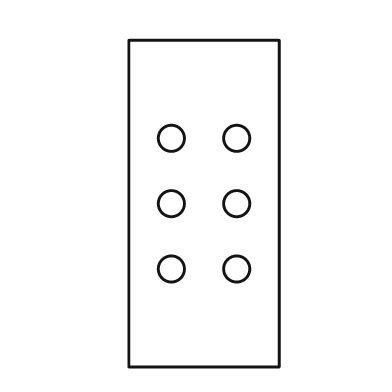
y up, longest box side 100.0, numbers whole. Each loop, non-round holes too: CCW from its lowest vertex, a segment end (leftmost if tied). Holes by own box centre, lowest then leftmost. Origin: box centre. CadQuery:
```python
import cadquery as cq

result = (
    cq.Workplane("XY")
    .moveTo(-23.0, -50.0)
    .lineTo(23.0, -50.0)
    .lineTo(23.0, 50.0)
    .lineTo(-23.0, 50.0)
    .close()
    .moveTo(-10.0, -20.0)
    .circle(4.0)
    .moveTo(10.0, -20.0)
    .circle(4.0)
    .moveTo(-10.0, 0.0)
    .circle(4.0)
    .moveTo(10.0, 0.0)
    .circle(4.0)
    .moveTo(-10.0, 20.0)
    .circle(4.0)
    .moveTo(10.0, 20.0)
    .circle(4.0)
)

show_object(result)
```